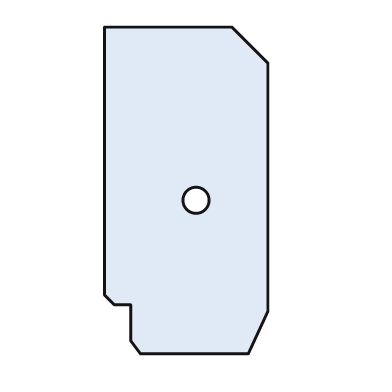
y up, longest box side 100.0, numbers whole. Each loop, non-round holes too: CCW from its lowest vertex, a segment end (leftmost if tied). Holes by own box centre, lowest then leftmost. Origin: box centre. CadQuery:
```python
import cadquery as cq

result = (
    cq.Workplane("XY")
    .moveTo(-14.0, -50.0)
    .lineTo(19.0, -50.0)
    .lineTo(25.0, -37.0)
    .lineTo(25.0, 39.0)
    .lineTo(14.0, 50.0)
    .lineTo(-25.0, 50.0)
    .lineTo(-25.0, -32.0)
    .lineTo(-22.0, -35.0)
    .lineTo(-17.0, -35.0)
    .lineTo(-17.0, -46.0)
    .close()
    .moveTo(3.0, -3.0)
    .circle(4.0)
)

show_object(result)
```